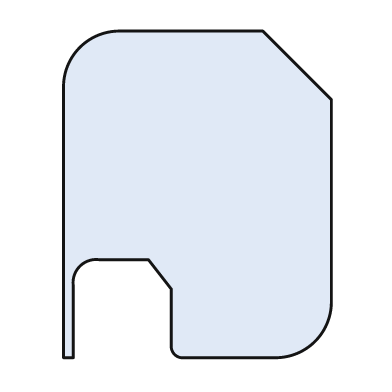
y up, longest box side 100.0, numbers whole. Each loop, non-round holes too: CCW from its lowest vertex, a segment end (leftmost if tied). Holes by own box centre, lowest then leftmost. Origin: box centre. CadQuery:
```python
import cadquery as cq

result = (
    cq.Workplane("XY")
    .moveTo(-41.0, -50.0)
    .lineTo(-38.0, -50.0)
    .lineTo(-38.0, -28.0)
    .threePointArc((-36.0, -22.0), (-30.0, -20.0))
    .lineTo(-15.0, -20.0)
    .lineTo(-8.0, -29.0)
    .lineTo(-8.0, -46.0)
    .threePointArc((-7.0, -49.0), (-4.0, -50.0))
    .lineTo(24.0, -50.0)
    .threePointArc((36.0, -45.0), (41.0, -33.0))
    .lineTo(41.0, 29.0)
    .lineTo(20.0, 50.0)
    .lineTo(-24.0, 50.0)
    .threePointArc((-36.0, 45.0), (-41.0, 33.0))
    .close()
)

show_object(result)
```